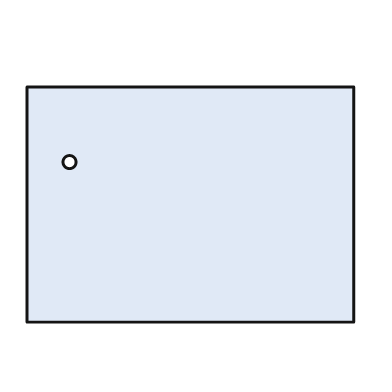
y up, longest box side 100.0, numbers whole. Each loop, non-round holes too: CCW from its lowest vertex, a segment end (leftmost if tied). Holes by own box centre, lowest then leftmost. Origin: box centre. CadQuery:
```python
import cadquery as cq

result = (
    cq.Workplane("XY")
    .moveTo(-50.0, -36.0)
    .lineTo(50.0, -36.0)
    .lineTo(50.0, 36.0)
    .lineTo(-50.0, 36.0)
    .close()
    .moveTo(-37.0, 13.0)
    .circle(2.0)
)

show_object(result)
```